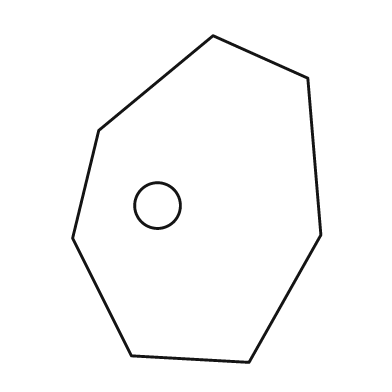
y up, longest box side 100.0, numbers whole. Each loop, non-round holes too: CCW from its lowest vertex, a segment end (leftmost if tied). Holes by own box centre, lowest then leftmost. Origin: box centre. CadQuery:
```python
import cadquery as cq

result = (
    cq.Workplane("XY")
    .moveTo(16.0, -50.0)
    .lineTo(38.0, -11.0)
    .lineTo(34.0, 37.0)
    .lineTo(5.0, 50.0)
    .lineTo(-30.0, 21.0)
    .lineTo(-38.0, -12.0)
    .lineTo(-20.0, -48.0)
    .close()
    .moveTo(-12.0, -2.0)
    .circle(7.0)
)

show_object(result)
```